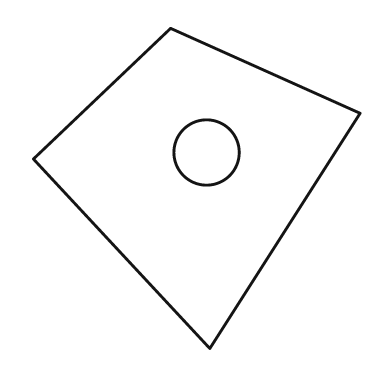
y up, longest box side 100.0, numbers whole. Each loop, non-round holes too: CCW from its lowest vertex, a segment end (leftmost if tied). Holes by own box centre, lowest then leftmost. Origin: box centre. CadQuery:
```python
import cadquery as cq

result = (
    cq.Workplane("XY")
    .moveTo(4.0, -49.0)
    .lineTo(50.0, 23.0)
    .lineTo(-8.0, 49.0)
    .lineTo(-50.0, 9.0)
    .close()
    .moveTo(3.0, 11.0)
    .circle(10.0)
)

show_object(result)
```